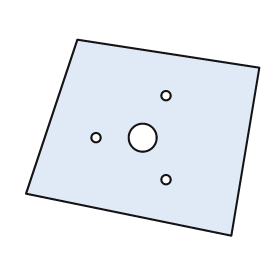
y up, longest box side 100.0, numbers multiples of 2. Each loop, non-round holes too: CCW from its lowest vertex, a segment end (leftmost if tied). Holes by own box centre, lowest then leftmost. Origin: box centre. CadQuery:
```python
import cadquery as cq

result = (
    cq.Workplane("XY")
    .moveTo(38.0, -42.0)
    .lineTo(50.0, 30.0)
    .lineTo(-28.0, 42.0)
    .lineTo(-50.0, -24.0)
    .close()
    .moveTo(10.0, -18.0)
    .circle(2.0)
    .moveTo(-20.0, 0.0)
    .circle(2.0)
    .moveTo(0.0, 0.0)
    .circle(6.0)
    .moveTo(10.0, 18.0)
    .circle(2.0)
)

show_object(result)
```